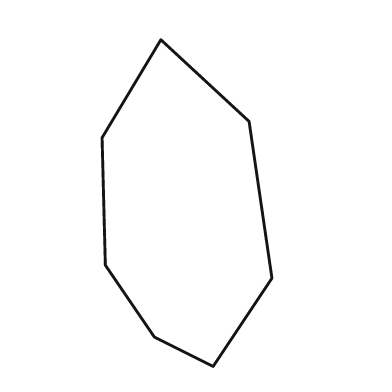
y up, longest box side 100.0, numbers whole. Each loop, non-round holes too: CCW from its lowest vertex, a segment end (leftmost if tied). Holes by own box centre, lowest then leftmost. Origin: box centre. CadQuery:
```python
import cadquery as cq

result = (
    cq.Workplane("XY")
    .moveTo(8.0, -50.0)
    .lineTo(26.0, -23.0)
    .lineTo(19.0, 25.0)
    .lineTo(-8.0, 50.0)
    .lineTo(-26.0, 20.0)
    .lineTo(-25.0, -19.0)
    .lineTo(-10.0, -41.0)
    .close()
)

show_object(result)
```